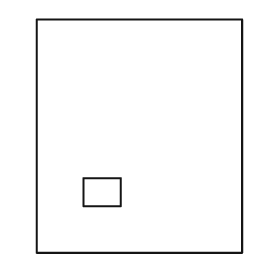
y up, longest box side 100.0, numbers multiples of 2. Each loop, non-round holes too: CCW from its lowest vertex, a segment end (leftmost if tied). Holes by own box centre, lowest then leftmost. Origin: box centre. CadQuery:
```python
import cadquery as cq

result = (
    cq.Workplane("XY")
    .moveTo(-44.0, -50.0)
    .lineTo(44.0, -50.0)
    .lineTo(44.0, 50.0)
    .lineTo(-44.0, 50.0)
    .close()
    .moveTo(-24.0, -30.0)
    .lineTo(-8.0, -30.0)
    .lineTo(-8.0, -18.0)
    .lineTo(-24.0, -18.0)
    .close()
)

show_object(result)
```